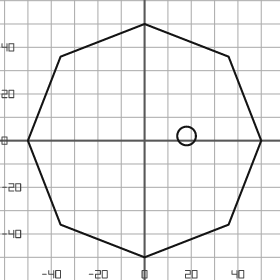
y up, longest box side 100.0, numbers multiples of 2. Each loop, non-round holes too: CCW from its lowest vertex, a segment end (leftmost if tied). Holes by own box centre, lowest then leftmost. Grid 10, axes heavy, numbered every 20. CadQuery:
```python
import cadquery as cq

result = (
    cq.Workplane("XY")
    .moveTo(0.0, -50.0)
    .lineTo(36.0, -36.0)
    .lineTo(50.0, 0.0)
    .lineTo(36.0, 36.0)
    .lineTo(0.0, 50.0)
    .lineTo(-36.0, 36.0)
    .lineTo(-50.0, 0.0)
    .lineTo(-36.0, -36.0)
    .close()
    .moveTo(18.0, 2.0)
    .circle(4.0)
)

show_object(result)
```